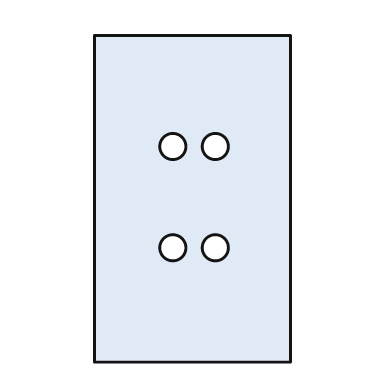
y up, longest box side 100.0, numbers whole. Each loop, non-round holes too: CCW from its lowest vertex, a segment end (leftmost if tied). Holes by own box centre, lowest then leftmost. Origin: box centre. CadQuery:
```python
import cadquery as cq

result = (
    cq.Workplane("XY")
    .moveTo(-30.0, -50.0)
    .lineTo(30.0, -50.0)
    .lineTo(30.0, 50.0)
    .lineTo(-30.0, 50.0)
    .close()
    .moveTo(-6.0, -15.0)
    .circle(4.0)
    .moveTo(7.0, -15.0)
    .circle(4.0)
    .moveTo(-6.0, 16.0)
    .circle(4.0)
    .moveTo(7.0, 16.0)
    .circle(4.0)
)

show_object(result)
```